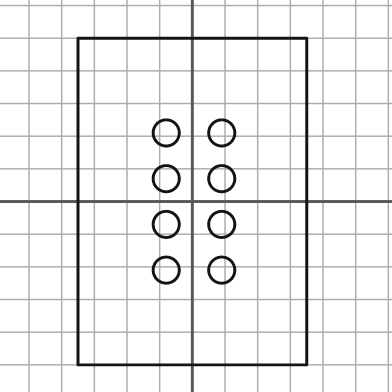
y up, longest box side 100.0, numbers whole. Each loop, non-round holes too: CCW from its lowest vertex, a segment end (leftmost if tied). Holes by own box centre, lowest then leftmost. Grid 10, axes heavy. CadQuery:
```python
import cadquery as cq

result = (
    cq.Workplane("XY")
    .moveTo(-35.0, -50.0)
    .lineTo(35.0, -50.0)
    .lineTo(35.0, 50.0)
    .lineTo(-35.0, 50.0)
    .close()
    .moveTo(-8.0, -21.0)
    .circle(4.0)
    .moveTo(9.0, -21.0)
    .circle(4.0)
    .moveTo(-8.0, -7.0)
    .circle(4.0)
    .moveTo(9.0, -7.0)
    .circle(4.0)
    .moveTo(-8.0, 7.0)
    .circle(4.0)
    .moveTo(9.0, 7.0)
    .circle(4.0)
    .moveTo(-8.0, 21.0)
    .circle(4.0)
    .moveTo(9.0, 21.0)
    .circle(4.0)
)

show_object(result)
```